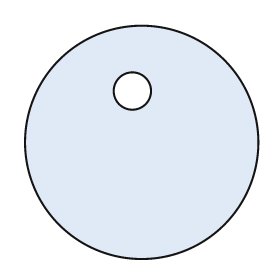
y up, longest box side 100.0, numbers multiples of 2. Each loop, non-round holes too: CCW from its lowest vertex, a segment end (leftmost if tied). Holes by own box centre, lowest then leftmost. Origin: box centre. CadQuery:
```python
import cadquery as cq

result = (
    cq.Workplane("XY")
    .moveTo(0.0, 0.0)
    .circle(50.0)
    .moveTo(-4.0, 22.0)
    .circle(8.0)
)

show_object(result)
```